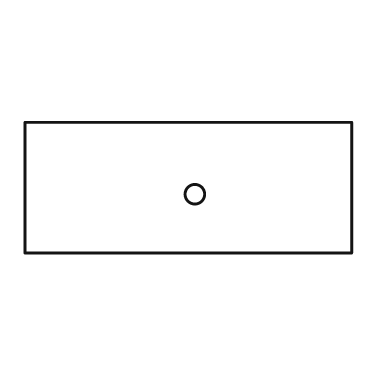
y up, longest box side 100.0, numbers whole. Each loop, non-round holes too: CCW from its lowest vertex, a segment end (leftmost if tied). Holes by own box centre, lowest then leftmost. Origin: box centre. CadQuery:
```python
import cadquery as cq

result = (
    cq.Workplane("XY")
    .moveTo(-50.0, -20.0)
    .lineTo(50.0, -20.0)
    .lineTo(50.0, 20.0)
    .lineTo(-50.0, 20.0)
    .close()
    .moveTo(2.0, -2.0)
    .circle(3.0)
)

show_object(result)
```